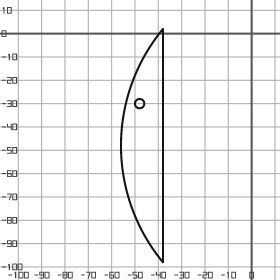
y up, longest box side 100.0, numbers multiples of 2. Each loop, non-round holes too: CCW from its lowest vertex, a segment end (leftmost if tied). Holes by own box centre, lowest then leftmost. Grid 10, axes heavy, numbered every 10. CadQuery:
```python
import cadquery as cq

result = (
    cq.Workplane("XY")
    .moveTo(-38.0, -98.0)
    .lineTo(-38.0, 2.0)
    .threePointArc((-56.0, -48.0), (-38.0, -98.0))
    .close()
    .moveTo(-48.0, -30.0)
    .circle(2.0)
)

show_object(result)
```